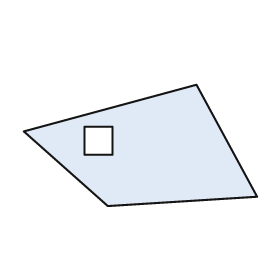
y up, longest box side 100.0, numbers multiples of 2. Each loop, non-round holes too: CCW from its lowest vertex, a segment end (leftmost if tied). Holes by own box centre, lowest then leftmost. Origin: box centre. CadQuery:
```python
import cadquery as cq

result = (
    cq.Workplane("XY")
    .moveTo(-14.0, -26.0)
    .lineTo(50.0, -22.0)
    .lineTo(24.0, 26.0)
    .lineTo(-50.0, 6.0)
    .close()
    .moveTo(-24.0, -4.0)
    .lineTo(-12.0, -4.0)
    .lineTo(-12.0, 8.0)
    .lineTo(-24.0, 8.0)
    .close()
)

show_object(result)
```